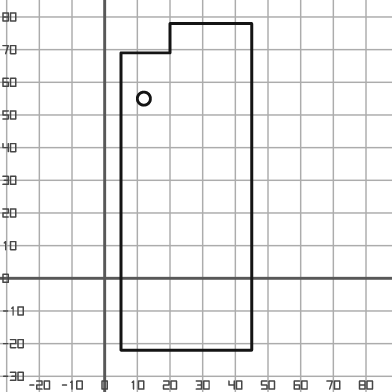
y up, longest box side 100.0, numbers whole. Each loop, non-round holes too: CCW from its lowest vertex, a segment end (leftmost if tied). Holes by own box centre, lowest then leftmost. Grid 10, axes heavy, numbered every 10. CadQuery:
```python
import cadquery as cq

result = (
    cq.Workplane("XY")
    .moveTo(5.0, -22.0)
    .lineTo(45.0, -22.0)
    .lineTo(45.0, 78.0)
    .lineTo(20.0, 78.0)
    .lineTo(20.0, 69.0)
    .lineTo(5.0, 69.0)
    .close()
    .moveTo(12.0, 55.0)
    .circle(2.0)
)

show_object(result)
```